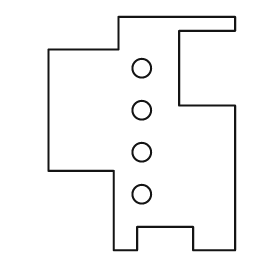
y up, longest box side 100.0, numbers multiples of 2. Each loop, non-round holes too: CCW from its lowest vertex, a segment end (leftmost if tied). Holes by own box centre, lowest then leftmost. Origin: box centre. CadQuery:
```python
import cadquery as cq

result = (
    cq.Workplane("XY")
    .moveTo(-12.0, -50.0)
    .lineTo(-2.0, -50.0)
    .lineTo(-2.0, -40.0)
    .lineTo(22.0, -40.0)
    .lineTo(22.0, -50.0)
    .lineTo(40.0, -50.0)
    .lineTo(40.0, 12.0)
    .lineTo(16.0, 12.0)
    .lineTo(16.0, 44.0)
    .lineTo(40.0, 44.0)
    .lineTo(40.0, 50.0)
    .lineTo(-10.0, 50.0)
    .lineTo(-10.0, 36.0)
    .lineTo(-40.0, 36.0)
    .lineTo(-40.0, -16.0)
    .lineTo(-12.0, -16.0)
    .close()
    .moveTo(0.0, -26.0)
    .circle(4.0)
    .moveTo(0.0, -8.0)
    .circle(4.0)
    .moveTo(0.0, 10.0)
    .circle(4.0)
    .moveTo(0.0, 28.0)
    .circle(4.0)
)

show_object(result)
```